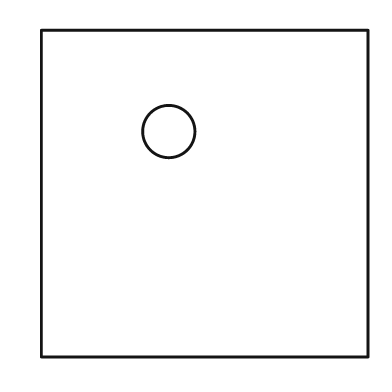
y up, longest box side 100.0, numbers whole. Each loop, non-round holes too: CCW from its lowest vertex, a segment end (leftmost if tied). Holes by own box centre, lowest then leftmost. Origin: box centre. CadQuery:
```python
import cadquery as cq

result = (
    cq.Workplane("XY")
    .moveTo(-50.0, -50.0)
    .lineTo(50.0, -50.0)
    .lineTo(50.0, 50.0)
    .lineTo(-50.0, 50.0)
    .close()
    .moveTo(-11.0, 19.0)
    .circle(8.0)
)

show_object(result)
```